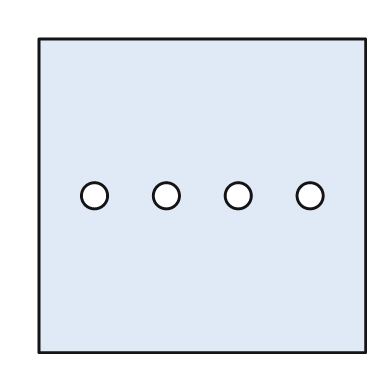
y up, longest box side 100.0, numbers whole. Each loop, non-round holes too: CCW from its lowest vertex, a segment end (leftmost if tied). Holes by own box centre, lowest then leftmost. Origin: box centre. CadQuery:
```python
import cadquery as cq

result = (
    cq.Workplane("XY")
    .moveTo(-50.0, -48.0)
    .lineTo(50.0, -48.0)
    .lineTo(50.0, 48.0)
    .lineTo(-50.0, 48.0)
    .close()
    .moveTo(-33.0, 0.0)
    .circle(4.0)
    .moveTo(-11.0, 0.0)
    .circle(4.0)
    .moveTo(11.0, 0.0)
    .circle(4.0)
    .moveTo(33.0, 0.0)
    .circle(4.0)
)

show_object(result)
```